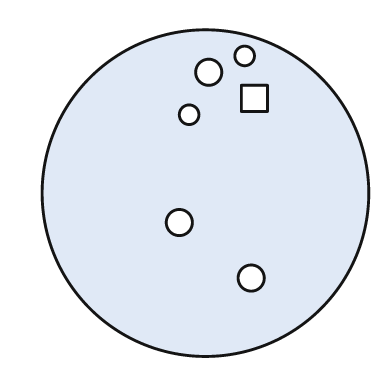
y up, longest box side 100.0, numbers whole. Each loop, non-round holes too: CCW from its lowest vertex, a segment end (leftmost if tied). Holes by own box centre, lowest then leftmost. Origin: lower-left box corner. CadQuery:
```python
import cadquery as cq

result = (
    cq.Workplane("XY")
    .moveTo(50.0, 50.0)
    .circle(50.0)
    .moveTo(64.0, 24.0)
    .circle(4.0)
    .moveTo(42.0, 41.0)
    .circle(4.0)
    .moveTo(45.0, 74.0)
    .circle(3.0)
    .moveTo(61.0, 75.0)
    .lineTo(69.0, 75.0)
    .lineTo(69.0, 83.0)
    .lineTo(61.0, 83.0)
    .close()
    .moveTo(51.0, 87.0)
    .circle(4.0)
    .moveTo(62.0, 92.0)
    .circle(3.0)
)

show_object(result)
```